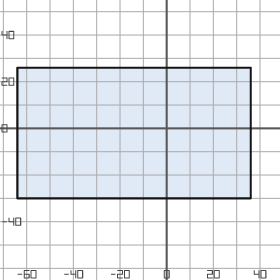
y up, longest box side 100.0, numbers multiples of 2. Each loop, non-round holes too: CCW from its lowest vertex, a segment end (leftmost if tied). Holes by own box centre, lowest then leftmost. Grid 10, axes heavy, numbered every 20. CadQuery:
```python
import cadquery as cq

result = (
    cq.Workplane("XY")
    .moveTo(-64.0, -30.0)
    .lineTo(36.0, -30.0)
    .lineTo(36.0, 26.0)
    .lineTo(-64.0, 26.0)
    .close()
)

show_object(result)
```